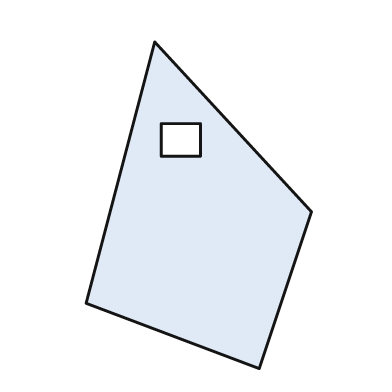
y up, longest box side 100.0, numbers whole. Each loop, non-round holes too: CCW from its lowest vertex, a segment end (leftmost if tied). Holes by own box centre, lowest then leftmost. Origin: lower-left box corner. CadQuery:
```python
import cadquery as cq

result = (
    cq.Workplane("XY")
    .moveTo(53.0, 0.0)
    .lineTo(69.0, 48.0)
    .lineTo(21.0, 100.0)
    .lineTo(0.0, 20.0)
    .close()
    .moveTo(23.0, 65.0)
    .lineTo(35.0, 65.0)
    .lineTo(35.0, 75.0)
    .lineTo(23.0, 75.0)
    .close()
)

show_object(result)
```